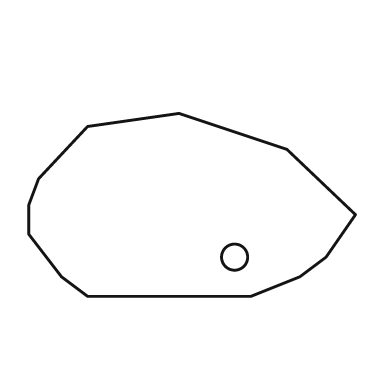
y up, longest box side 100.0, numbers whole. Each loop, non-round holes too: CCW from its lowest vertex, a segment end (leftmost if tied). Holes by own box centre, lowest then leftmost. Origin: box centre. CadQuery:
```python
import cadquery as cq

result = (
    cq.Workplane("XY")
    .moveTo(-32.0, -28.0)
    .lineTo(18.0, -28.0)
    .lineTo(33.0, -22.0)
    .lineTo(41.0, -16.0)
    .lineTo(50.0, -3.0)
    .lineTo(29.0, 17.0)
    .lineTo(-4.0, 28.0)
    .lineTo(-32.0, 24.0)
    .lineTo(-47.0, 8.0)
    .lineTo(-50.0, 0.0)
    .lineTo(-50.0, -9.0)
    .lineTo(-40.0, -22.0)
    .close()
    .moveTo(13.0, -16.0)
    .circle(4.0)
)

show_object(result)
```